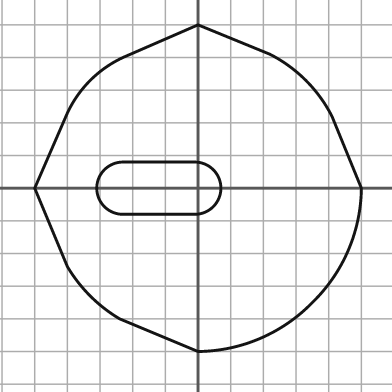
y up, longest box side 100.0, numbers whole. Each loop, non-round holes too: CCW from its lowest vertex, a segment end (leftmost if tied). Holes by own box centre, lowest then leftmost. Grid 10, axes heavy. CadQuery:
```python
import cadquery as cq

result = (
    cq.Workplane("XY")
    .moveTo(0.0, -50.0)
    .threePointArc((19.0, -46.0), (35.0, -35.0))
    .threePointArc((46.0, -19.0), (50.0, 0.0))
    .lineTo(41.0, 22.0)
    .threePointArc((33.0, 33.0), (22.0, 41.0))
    .lineTo(0.0, 50.0)
    .lineTo(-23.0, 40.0)
    .threePointArc((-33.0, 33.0), (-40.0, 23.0))
    .lineTo(-50.0, 0.0)
    .lineTo(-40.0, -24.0)
    .threePointArc((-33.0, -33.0), (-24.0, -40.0))
    .close()
    .moveTo(-23.0, -8.0)
    .lineTo(-1.0, -8.0)
    .threePointArc((7.0, 0.0), (-1.0, 8.0))
    .lineTo(-23.0, 8.0)
    .threePointArc((-31.0, 0.0), (-23.0, -8.0))
    .close()
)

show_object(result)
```